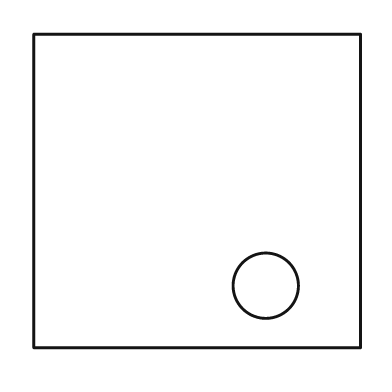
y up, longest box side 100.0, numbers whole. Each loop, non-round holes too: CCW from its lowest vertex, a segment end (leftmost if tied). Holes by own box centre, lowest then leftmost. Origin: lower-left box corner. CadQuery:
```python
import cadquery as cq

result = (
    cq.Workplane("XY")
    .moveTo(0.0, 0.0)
    .lineTo(100.0, 0.0)
    .lineTo(100.0, 96.0)
    .lineTo(0.0, 96.0)
    .close()
    .moveTo(71.0, 19.0)
    .circle(10.0)
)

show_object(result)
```